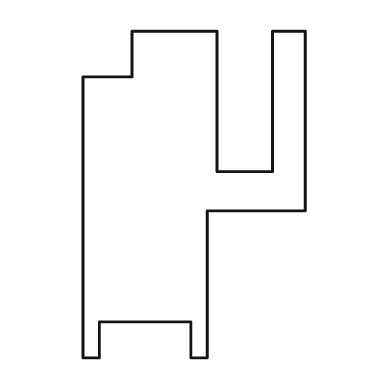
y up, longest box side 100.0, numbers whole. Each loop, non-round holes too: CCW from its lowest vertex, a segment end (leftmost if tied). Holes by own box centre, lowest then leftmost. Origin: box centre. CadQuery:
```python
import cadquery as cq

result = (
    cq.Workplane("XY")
    .moveTo(-34.0, -50.0)
    .lineTo(-29.0, -50.0)
    .lineTo(-29.0, -39.0)
    .lineTo(-1.0, -39.0)
    .lineTo(-1.0, -50.0)
    .lineTo(4.0, -50.0)
    .lineTo(4.0, -5.0)
    .lineTo(34.0, -5.0)
    .lineTo(34.0, 50.0)
    .lineTo(24.0, 50.0)
    .lineTo(24.0, 7.0)
    .lineTo(7.0, 7.0)
    .lineTo(7.0, 50.0)
    .lineTo(-19.0, 50.0)
    .lineTo(-19.0, 36.0)
    .lineTo(-34.0, 36.0)
    .close()
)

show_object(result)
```